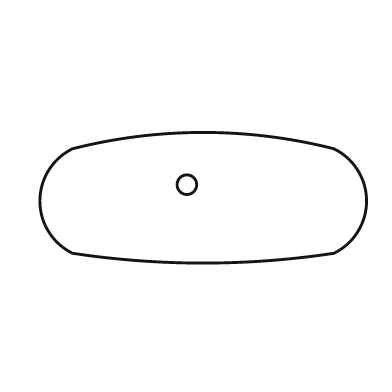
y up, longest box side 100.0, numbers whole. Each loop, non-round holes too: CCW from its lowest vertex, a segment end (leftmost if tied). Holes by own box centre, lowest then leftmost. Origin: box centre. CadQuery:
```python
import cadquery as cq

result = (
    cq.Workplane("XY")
    .moveTo(-40.0, -17.0)
    .threePointArc((0.0, -20.0), (40.0, -17.0))
    .threePointArc((50.0, -1.0), (40.0, 15.0))
    .threePointArc((0.0, 20.0), (-40.0, 15.0))
    .threePointArc((-50.0, -1.0), (-40.0, -17.0))
    .close()
    .moveTo(-5.0, 4.0)
    .circle(3.0)
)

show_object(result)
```